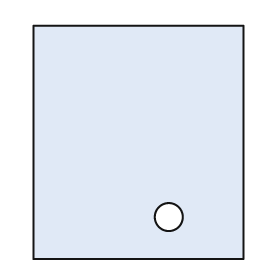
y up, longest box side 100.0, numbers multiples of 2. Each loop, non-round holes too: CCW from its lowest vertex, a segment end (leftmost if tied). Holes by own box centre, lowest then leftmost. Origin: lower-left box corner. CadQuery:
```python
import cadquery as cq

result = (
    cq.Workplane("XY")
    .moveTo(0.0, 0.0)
    .lineTo(90.0, 0.0)
    .lineTo(90.0, 100.0)
    .lineTo(0.0, 100.0)
    .close()
    .moveTo(58.0, 18.0)
    .circle(6.0)
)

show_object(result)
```